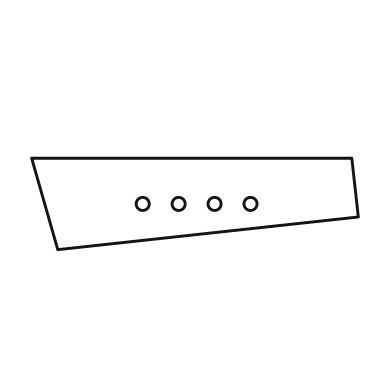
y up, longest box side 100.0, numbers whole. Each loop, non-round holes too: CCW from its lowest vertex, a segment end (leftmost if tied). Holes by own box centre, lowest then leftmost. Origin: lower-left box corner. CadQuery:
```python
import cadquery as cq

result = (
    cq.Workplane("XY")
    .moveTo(8.0, 0.0)
    .lineTo(100.0, 10.0)
    .lineTo(98.0, 28.0)
    .lineTo(0.0, 28.0)
    .close()
    .moveTo(34.0, 14.0)
    .circle(2.0)
    .moveTo(45.0, 14.0)
    .circle(2.0)
    .moveTo(56.0, 14.0)
    .circle(2.0)
    .moveTo(67.0, 14.0)
    .circle(2.0)
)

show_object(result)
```